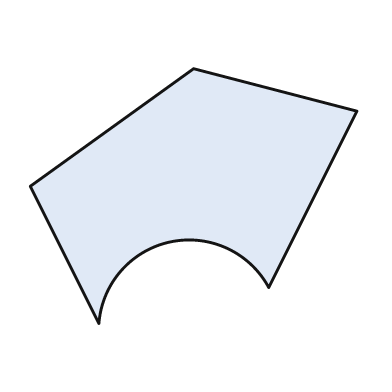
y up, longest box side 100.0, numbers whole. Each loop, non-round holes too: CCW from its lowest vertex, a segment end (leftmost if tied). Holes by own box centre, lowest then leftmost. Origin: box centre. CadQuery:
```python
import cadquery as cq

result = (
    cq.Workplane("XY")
    .moveTo(-29.0, -39.0)
    .threePointArc((-7.0, -14.0), (23.0, -28.0))
    .lineTo(50.0, 26.0)
    .lineTo(0.0, 39.0)
    .lineTo(-50.0, 3.0)
    .close()
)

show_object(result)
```